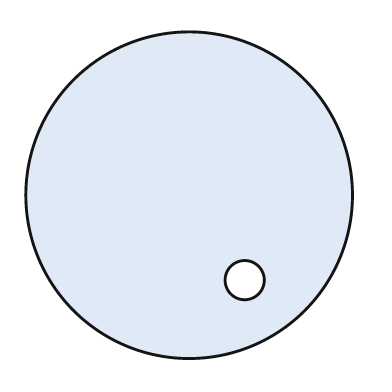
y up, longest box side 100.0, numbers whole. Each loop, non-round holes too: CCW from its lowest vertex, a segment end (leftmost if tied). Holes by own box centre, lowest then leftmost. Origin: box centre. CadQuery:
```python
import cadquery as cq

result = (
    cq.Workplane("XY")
    .moveTo(0.0, 0.0)
    .circle(50.0)
    .moveTo(17.0, -26.0)
    .circle(6.0)
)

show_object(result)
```